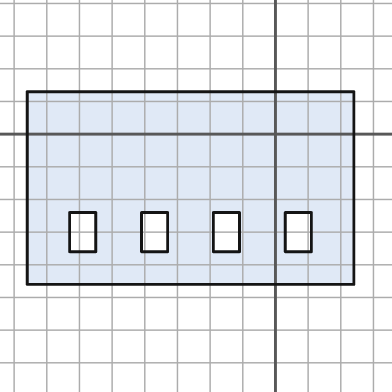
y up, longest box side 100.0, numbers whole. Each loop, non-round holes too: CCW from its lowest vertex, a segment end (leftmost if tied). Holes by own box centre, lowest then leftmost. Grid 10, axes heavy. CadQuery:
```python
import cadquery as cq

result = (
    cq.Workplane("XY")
    .moveTo(-76.0, -46.0)
    .lineTo(24.0, -46.0)
    .lineTo(24.0, 13.0)
    .lineTo(-76.0, 13.0)
    .close()
    .moveTo(-63.0, -36.0)
    .lineTo(-55.0, -36.0)
    .lineTo(-55.0, -24.0)
    .lineTo(-63.0, -24.0)
    .close()
    .moveTo(-41.0, -36.0)
    .lineTo(-33.0, -36.0)
    .lineTo(-33.0, -24.0)
    .lineTo(-41.0, -24.0)
    .close()
    .moveTo(-19.0, -36.0)
    .lineTo(-11.0, -36.0)
    .lineTo(-11.0, -24.0)
    .lineTo(-19.0, -24.0)
    .close()
    .moveTo(3.0, -36.0)
    .lineTo(11.0, -36.0)
    .lineTo(11.0, -24.0)
    .lineTo(3.0, -24.0)
    .close()
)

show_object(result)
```